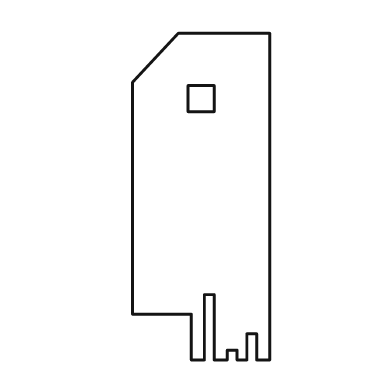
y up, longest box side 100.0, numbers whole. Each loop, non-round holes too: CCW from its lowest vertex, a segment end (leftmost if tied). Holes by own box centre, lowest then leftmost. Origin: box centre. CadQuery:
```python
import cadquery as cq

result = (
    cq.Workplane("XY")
    .moveTo(-3.0, -50.0)
    .lineTo(1.0, -50.0)
    .lineTo(1.0, -30.0)
    .lineTo(4.0, -30.0)
    .lineTo(4.0, -50.0)
    .lineTo(8.0, -50.0)
    .lineTo(8.0, -47.0)
    .lineTo(11.0, -47.0)
    .lineTo(11.0, -50.0)
    .lineTo(14.0, -50.0)
    .lineTo(14.0, -42.0)
    .lineTo(17.0, -42.0)
    .lineTo(17.0, -50.0)
    .lineTo(21.0, -50.0)
    .lineTo(21.0, 50.0)
    .lineTo(-7.0, 50.0)
    .lineTo(-21.0, 35.0)
    .lineTo(-21.0, -36.0)
    .lineTo(-3.0, -36.0)
    .close()
    .moveTo(-4.0, 26.0)
    .lineTo(4.0, 26.0)
    .lineTo(4.0, 34.0)
    .lineTo(-4.0, 34.0)
    .close()
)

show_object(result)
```